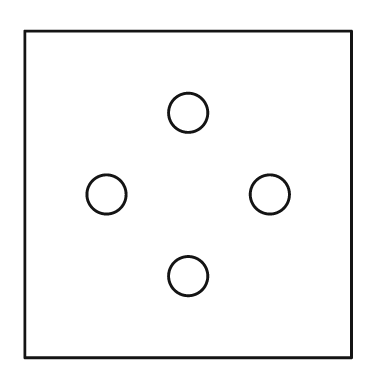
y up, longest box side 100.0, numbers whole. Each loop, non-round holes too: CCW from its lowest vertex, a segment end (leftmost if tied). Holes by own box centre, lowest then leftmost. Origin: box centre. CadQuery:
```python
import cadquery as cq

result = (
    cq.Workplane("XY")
    .moveTo(-50.0, -50.0)
    .lineTo(50.0, -50.0)
    .lineTo(50.0, 50.0)
    .lineTo(-50.0, 50.0)
    .close()
    .moveTo(0.0, -25.0)
    .circle(6.0)
    .moveTo(-25.0, 0.0)
    .circle(6.0)
    .moveTo(25.0, 0.0)
    .circle(6.0)
    .moveTo(0.0, 25.0)
    .circle(6.0)
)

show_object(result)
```